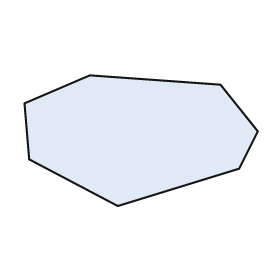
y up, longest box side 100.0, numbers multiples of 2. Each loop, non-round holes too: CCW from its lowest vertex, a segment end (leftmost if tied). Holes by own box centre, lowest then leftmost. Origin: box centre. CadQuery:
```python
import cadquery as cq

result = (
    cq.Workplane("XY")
    .moveTo(-10.0, -28.0)
    .lineTo(42.0, -12.0)
    .lineTo(50.0, 4.0)
    .lineTo(34.0, 24.0)
    .lineTo(-22.0, 28.0)
    .lineTo(-50.0, 16.0)
    .lineTo(-48.0, -8.0)
    .close()
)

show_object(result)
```